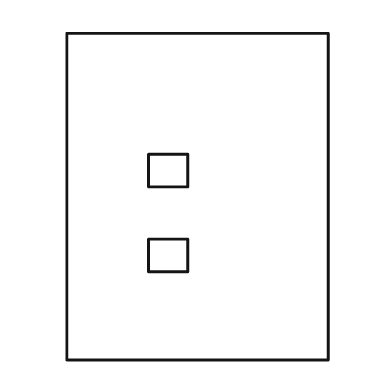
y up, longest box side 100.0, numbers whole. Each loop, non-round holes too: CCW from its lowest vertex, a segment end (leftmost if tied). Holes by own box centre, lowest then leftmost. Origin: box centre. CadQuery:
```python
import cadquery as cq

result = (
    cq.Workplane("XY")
    .moveTo(-40.0, -50.0)
    .lineTo(40.0, -50.0)
    .lineTo(40.0, 50.0)
    .lineTo(-40.0, 50.0)
    .close()
    .moveTo(-15.0, -23.0)
    .lineTo(-3.0, -23.0)
    .lineTo(-3.0, -13.0)
    .lineTo(-15.0, -13.0)
    .close()
    .moveTo(-15.0, 3.0)
    .lineTo(-3.0, 3.0)
    .lineTo(-3.0, 13.0)
    .lineTo(-15.0, 13.0)
    .close()
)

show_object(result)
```